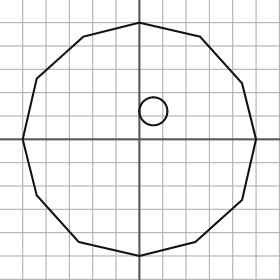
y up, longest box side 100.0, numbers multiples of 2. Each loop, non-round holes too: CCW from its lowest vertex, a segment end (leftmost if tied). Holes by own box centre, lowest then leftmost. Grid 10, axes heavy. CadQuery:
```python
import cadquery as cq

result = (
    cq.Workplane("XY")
    .moveTo(0.0, -50.0)
    .lineTo(24.0, -44.0)
    .lineTo(44.0, -26.0)
    .lineTo(50.0, 0.0)
    .lineTo(44.0, 24.0)
    .lineTo(26.0, 44.0)
    .lineTo(0.0, 50.0)
    .lineTo(-24.0, 44.0)
    .lineTo(-44.0, 26.0)
    .lineTo(-50.0, 0.0)
    .lineTo(-44.0, -24.0)
    .lineTo(-26.0, -44.0)
    .close()
    .moveTo(6.0, 12.0)
    .circle(6.0)
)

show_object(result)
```